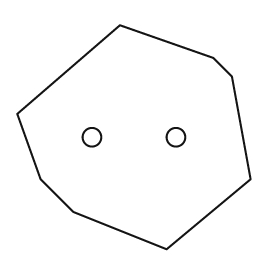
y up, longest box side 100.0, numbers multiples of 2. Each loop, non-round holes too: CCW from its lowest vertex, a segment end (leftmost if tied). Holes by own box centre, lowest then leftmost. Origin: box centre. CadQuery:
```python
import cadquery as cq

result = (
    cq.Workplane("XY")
    .moveTo(14.0, -48.0)
    .lineTo(50.0, -18.0)
    .lineTo(42.0, 26.0)
    .lineTo(34.0, 34.0)
    .lineTo(-6.0, 48.0)
    .lineTo(-50.0, 10.0)
    .lineTo(-40.0, -18.0)
    .lineTo(-26.0, -32.0)
    .close()
    .moveTo(-18.0, 0.0)
    .circle(4.0)
    .moveTo(18.0, 0.0)
    .circle(4.0)
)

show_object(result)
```